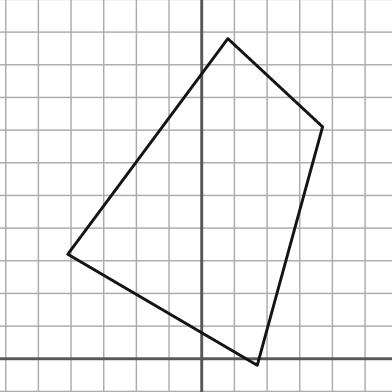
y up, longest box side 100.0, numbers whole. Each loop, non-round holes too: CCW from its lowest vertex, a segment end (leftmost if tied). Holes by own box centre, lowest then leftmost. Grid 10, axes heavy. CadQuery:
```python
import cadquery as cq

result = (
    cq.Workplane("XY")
    .moveTo(17.0, -2.0)
    .lineTo(37.0, 71.0)
    .lineTo(8.0, 98.0)
    .lineTo(-41.0, 32.0)
    .close()
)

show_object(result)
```